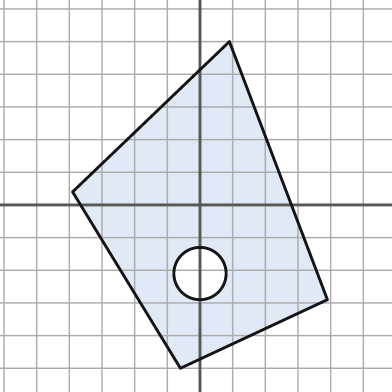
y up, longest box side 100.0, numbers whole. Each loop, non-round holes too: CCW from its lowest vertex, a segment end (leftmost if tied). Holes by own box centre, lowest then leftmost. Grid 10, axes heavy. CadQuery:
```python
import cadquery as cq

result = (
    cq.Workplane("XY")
    .moveTo(-6.0, -50.0)
    .lineTo(39.0, -29.0)
    .lineTo(9.0, 50.0)
    .lineTo(-39.0, 4.0)
    .close()
    .moveTo(0.0, -21.0)
    .circle(8.0)
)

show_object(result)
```